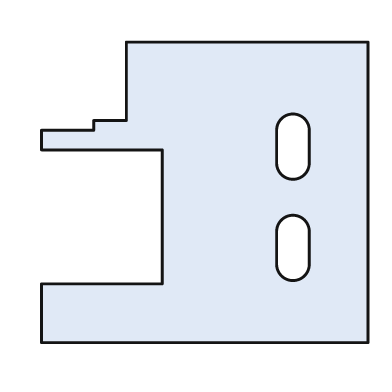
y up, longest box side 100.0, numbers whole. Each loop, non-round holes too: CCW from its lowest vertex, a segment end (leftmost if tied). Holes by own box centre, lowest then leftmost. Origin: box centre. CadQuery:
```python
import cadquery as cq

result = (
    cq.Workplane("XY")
    .moveTo(-50.0, -46.0)
    .lineTo(50.0, -46.0)
    .lineTo(50.0, 46.0)
    .lineTo(-24.0, 46.0)
    .lineTo(-24.0, 22.0)
    .lineTo(-34.0, 22.0)
    .lineTo(-34.0, 19.0)
    .lineTo(-50.0, 19.0)
    .lineTo(-50.0, 13.0)
    .lineTo(-13.0, 13.0)
    .lineTo(-13.0, -28.0)
    .lineTo(-50.0, -28.0)
    .close()
    .moveTo(22.0, -22.0)
    .threePointArc((27.0, -27.0), (32.0, -22.0))
    .lineTo(32.0, -12.0)
    .threePointArc((27.0, -7.0), (22.0, -12.0))
    .close()
    .moveTo(22.0, 9.0)
    .threePointArc((27.0, 4.0), (32.0, 9.0))
    .lineTo(32.0, 19.0)
    .threePointArc((27.0, 24.0), (22.0, 19.0))
    .close()
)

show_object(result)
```